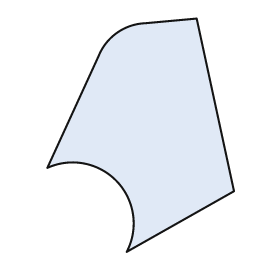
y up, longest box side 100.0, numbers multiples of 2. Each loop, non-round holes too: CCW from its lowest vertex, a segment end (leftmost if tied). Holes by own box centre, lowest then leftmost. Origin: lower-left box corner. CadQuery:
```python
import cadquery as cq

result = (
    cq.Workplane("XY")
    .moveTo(34.0, 0.0)
    .lineTo(80.0, 26.0)
    .lineTo(64.0, 100.0)
    .lineTo(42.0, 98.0)
    .threePointArc((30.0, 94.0), (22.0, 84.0))
    .lineTo(0.0, 36.0)
    .threePointArc((30.0, 30.0), (34.0, 0.0))
    .close()
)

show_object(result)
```